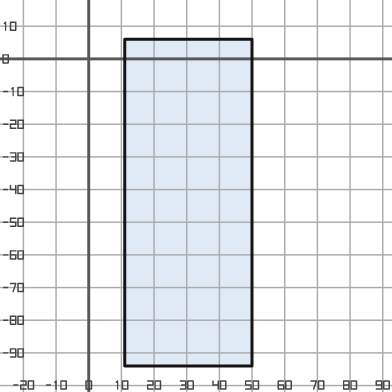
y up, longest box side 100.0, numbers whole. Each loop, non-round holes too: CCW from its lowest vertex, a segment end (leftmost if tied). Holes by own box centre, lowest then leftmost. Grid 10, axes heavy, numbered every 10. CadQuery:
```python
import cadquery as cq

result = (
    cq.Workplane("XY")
    .moveTo(11.0, -94.0)
    .lineTo(50.0, -94.0)
    .lineTo(50.0, 6.0)
    .lineTo(11.0, 6.0)
    .close()
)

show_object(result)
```